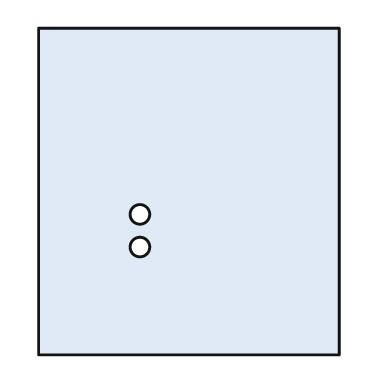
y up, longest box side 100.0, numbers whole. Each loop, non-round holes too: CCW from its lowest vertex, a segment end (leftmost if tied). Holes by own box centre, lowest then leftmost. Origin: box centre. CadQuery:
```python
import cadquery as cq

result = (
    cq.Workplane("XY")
    .moveTo(-46.0, -50.0)
    .lineTo(46.0, -50.0)
    .lineTo(46.0, 50.0)
    .lineTo(-46.0, 50.0)
    .close()
    .moveTo(-15.0, -17.0)
    .circle(3.0)
    .moveTo(-15.0, -7.0)
    .circle(3.0)
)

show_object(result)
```